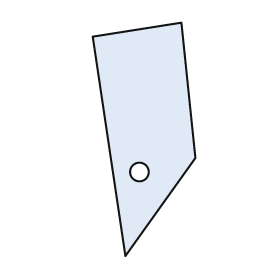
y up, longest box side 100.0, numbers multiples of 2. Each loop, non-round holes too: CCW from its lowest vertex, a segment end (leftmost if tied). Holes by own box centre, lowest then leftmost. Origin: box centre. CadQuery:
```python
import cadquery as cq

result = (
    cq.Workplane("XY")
    .moveTo(-8.0, -50.0)
    .lineTo(22.0, -8.0)
    .lineTo(16.0, 50.0)
    .lineTo(-22.0, 44.0)
    .close()
    .moveTo(-2.0, -14.0)
    .circle(4.0)
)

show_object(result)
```